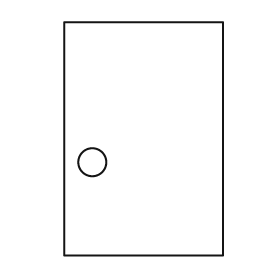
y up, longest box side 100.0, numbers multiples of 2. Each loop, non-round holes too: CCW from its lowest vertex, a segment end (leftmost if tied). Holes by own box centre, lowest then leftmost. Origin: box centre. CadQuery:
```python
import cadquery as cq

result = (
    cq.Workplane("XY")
    .moveTo(-34.0, -50.0)
    .lineTo(34.0, -50.0)
    .lineTo(34.0, 50.0)
    .lineTo(-34.0, 50.0)
    .close()
    .moveTo(-22.0, -10.0)
    .circle(6.0)
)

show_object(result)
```